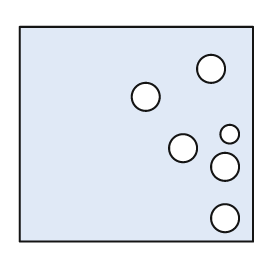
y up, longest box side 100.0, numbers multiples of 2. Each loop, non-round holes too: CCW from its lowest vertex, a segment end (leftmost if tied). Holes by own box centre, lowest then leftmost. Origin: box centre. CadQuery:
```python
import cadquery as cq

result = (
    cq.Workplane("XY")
    .moveTo(-50.0, -46.0)
    .lineTo(50.0, -46.0)
    .lineTo(50.0, 46.0)
    .lineTo(-50.0, 46.0)
    .close()
    .moveTo(38.0, -36.0)
    .circle(6.0)
    .moveTo(38.0, -14.0)
    .circle(6.0)
    .moveTo(20.0, -6.0)
    .circle(6.0)
    .moveTo(40.0, 0.0)
    .circle(4.0)
    .moveTo(4.0, 16.0)
    .circle(6.0)
    .moveTo(32.0, 28.0)
    .circle(6.0)
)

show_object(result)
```